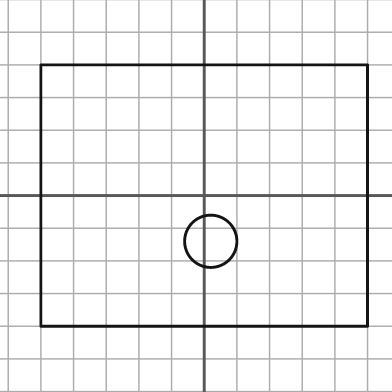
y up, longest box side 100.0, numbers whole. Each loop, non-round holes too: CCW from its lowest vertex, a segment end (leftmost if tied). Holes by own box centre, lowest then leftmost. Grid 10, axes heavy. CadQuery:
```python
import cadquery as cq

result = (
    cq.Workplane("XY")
    .moveTo(-50.0, -40.0)
    .lineTo(50.0, -40.0)
    .lineTo(50.0, 40.0)
    .lineTo(-50.0, 40.0)
    .close()
    .moveTo(2.0, -14.0)
    .circle(8.0)
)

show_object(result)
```